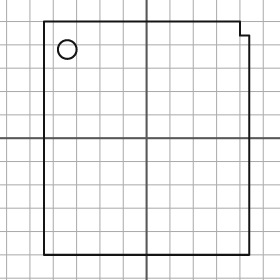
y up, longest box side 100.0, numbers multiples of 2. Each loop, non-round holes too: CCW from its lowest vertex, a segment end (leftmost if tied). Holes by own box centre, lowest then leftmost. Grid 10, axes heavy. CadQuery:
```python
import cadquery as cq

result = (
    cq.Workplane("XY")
    .moveTo(-44.0, -50.0)
    .lineTo(44.0, -50.0)
    .lineTo(44.0, 44.0)
    .lineTo(40.0, 44.0)
    .lineTo(40.0, 50.0)
    .lineTo(-44.0, 50.0)
    .close()
    .moveTo(-34.0, 38.0)
    .circle(4.0)
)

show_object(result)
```